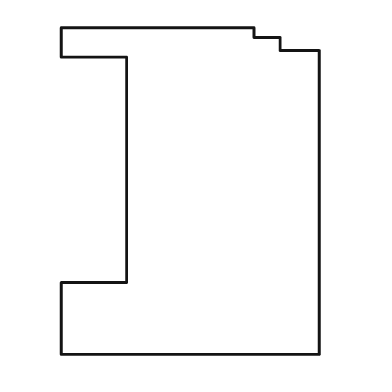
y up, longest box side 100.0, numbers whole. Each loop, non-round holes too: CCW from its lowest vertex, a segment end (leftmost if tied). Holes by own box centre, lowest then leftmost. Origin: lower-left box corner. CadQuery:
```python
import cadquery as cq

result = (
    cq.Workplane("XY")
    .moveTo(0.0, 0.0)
    .lineTo(79.0, 0.0)
    .lineTo(79.0, 93.0)
    .lineTo(67.0, 93.0)
    .lineTo(67.0, 97.0)
    .lineTo(59.0, 97.0)
    .lineTo(59.0, 100.0)
    .lineTo(0.0, 100.0)
    .lineTo(0.0, 91.0)
    .lineTo(20.0, 91.0)
    .lineTo(20.0, 22.0)
    .lineTo(0.0, 22.0)
    .close()
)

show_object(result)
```